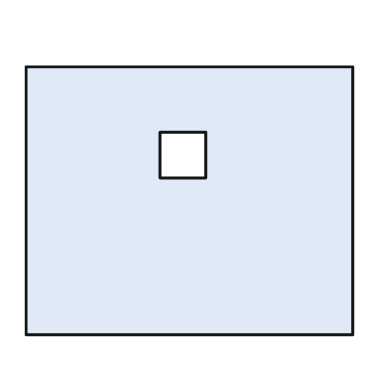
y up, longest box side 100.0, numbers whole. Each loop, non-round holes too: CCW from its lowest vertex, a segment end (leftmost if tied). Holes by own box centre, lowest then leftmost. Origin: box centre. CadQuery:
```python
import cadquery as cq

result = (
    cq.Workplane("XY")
    .moveTo(-50.0, -41.0)
    .lineTo(50.0, -41.0)
    .lineTo(50.0, 41.0)
    .lineTo(-50.0, 41.0)
    .close()
    .moveTo(-9.0, 7.0)
    .lineTo(5.0, 7.0)
    .lineTo(5.0, 21.0)
    .lineTo(-9.0, 21.0)
    .close()
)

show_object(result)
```